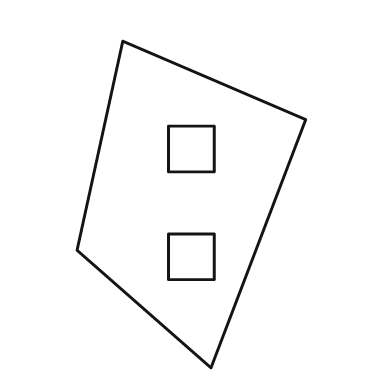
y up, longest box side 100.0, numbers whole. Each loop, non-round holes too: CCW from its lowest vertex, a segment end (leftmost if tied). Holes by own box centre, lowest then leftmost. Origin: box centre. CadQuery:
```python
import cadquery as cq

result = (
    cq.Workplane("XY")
    .moveTo(6.0, -50.0)
    .lineTo(35.0, 26.0)
    .lineTo(-21.0, 50.0)
    .lineTo(-35.0, -14.0)
    .close()
    .moveTo(-7.0, -23.0)
    .lineTo(7.0, -23.0)
    .lineTo(7.0, -9.0)
    .lineTo(-7.0, -9.0)
    .close()
    .moveTo(-7.0, 10.0)
    .lineTo(7.0, 10.0)
    .lineTo(7.0, 24.0)
    .lineTo(-7.0, 24.0)
    .close()
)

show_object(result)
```